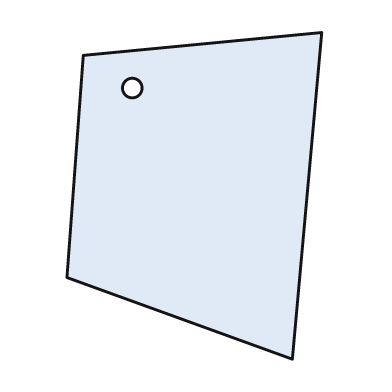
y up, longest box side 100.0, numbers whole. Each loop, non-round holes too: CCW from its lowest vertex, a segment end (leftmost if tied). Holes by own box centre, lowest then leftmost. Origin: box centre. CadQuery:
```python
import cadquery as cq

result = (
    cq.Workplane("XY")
    .moveTo(30.0, -50.0)
    .lineTo(39.0, 50.0)
    .lineTo(-34.0, 43.0)
    .lineTo(-39.0, -25.0)
    .close()
    .moveTo(-19.0, 33.0)
    .circle(3.0)
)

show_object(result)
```